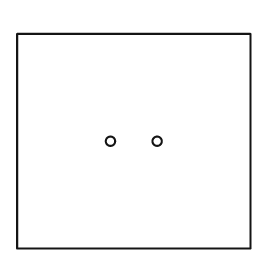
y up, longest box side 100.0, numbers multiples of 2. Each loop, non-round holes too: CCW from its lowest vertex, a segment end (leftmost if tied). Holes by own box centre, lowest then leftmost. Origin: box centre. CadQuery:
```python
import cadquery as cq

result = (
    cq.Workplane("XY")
    .moveTo(-50.0, -46.0)
    .lineTo(50.0, -46.0)
    .lineTo(50.0, 46.0)
    .lineTo(-50.0, 46.0)
    .close()
    .moveTo(-10.0, 0.0)
    .circle(2.0)
    .moveTo(10.0, 0.0)
    .circle(2.0)
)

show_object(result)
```